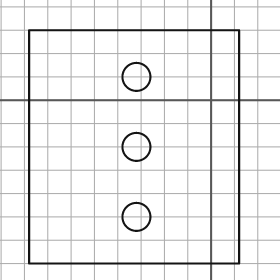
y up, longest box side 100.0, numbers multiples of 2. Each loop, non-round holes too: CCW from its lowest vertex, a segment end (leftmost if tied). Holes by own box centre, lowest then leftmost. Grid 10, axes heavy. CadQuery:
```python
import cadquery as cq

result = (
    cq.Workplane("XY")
    .moveTo(-78.0, -70.0)
    .lineTo(12.0, -70.0)
    .lineTo(12.0, 30.0)
    .lineTo(-78.0, 30.0)
    .close()
    .moveTo(-32.0, -50.0)
    .circle(6.0)
    .moveTo(-32.0, -20.0)
    .circle(6.0)
    .moveTo(-32.0, 10.0)
    .circle(6.0)
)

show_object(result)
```